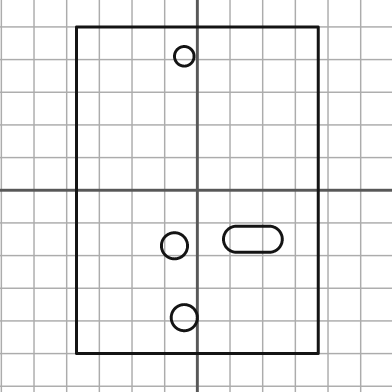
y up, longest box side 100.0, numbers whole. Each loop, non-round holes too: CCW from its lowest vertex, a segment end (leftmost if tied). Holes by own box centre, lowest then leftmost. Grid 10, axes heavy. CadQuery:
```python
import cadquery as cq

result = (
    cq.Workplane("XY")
    .moveTo(-37.0, -50.0)
    .lineTo(37.0, -50.0)
    .lineTo(37.0, 50.0)
    .lineTo(-37.0, 50.0)
    .close()
    .moveTo(-4.0, -39.0)
    .circle(4.0)
    .moveTo(-7.0, -17.0)
    .circle(4.0)
    .moveTo(12.0, -19.0)
    .lineTo(22.0, -19.0)
    .threePointArc((26.0, -15.0), (22.0, -11.0))
    .lineTo(12.0, -11.0)
    .threePointArc((8.0, -15.0), (12.0, -19.0))
    .close()
    .moveTo(-4.0, 41.0)
    .circle(3.0)
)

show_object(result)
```